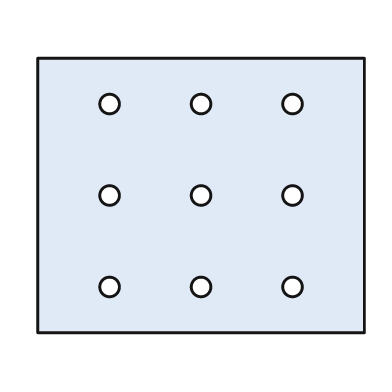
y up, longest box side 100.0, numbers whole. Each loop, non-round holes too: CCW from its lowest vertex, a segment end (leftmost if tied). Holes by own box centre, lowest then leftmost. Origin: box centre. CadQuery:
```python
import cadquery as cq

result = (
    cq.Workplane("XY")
    .moveTo(-50.0, -42.0)
    .lineTo(50.0, -42.0)
    .lineTo(50.0, 42.0)
    .lineTo(-50.0, 42.0)
    .close()
    .moveTo(-28.0, -28.0)
    .circle(3.0)
    .moveTo(0.0, -28.0)
    .circle(3.0)
    .moveTo(28.0, -28.0)
    .circle(3.0)
    .moveTo(-28.0, 0.0)
    .circle(3.0)
    .moveTo(0.0, 0.0)
    .circle(3.0)
    .moveTo(28.0, 0.0)
    .circle(3.0)
    .moveTo(-28.0, 28.0)
    .circle(3.0)
    .moveTo(0.0, 28.0)
    .circle(3.0)
    .moveTo(28.0, 28.0)
    .circle(3.0)
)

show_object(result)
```